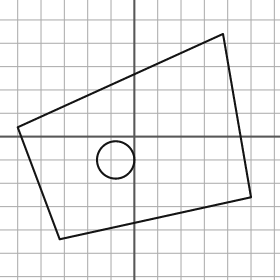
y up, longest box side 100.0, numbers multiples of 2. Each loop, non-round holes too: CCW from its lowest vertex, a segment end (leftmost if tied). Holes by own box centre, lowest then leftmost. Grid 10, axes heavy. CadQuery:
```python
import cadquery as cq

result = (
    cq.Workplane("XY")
    .moveTo(-32.0, -44.0)
    .lineTo(50.0, -26.0)
    .lineTo(38.0, 44.0)
    .lineTo(-50.0, 4.0)
    .close()
    .moveTo(-8.0, -10.0)
    .circle(8.0)
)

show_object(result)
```